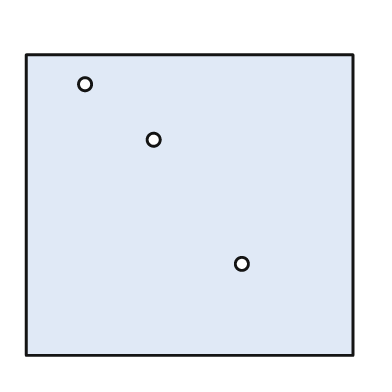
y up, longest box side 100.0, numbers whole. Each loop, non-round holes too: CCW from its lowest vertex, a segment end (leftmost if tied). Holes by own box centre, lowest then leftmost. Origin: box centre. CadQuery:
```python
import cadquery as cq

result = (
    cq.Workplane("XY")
    .moveTo(-50.0, -46.0)
    .lineTo(50.0, -46.0)
    .lineTo(50.0, 46.0)
    .lineTo(-50.0, 46.0)
    .close()
    .moveTo(16.0, -18.0)
    .circle(2.0)
    .moveTo(-11.0, 20.0)
    .circle(2.0)
    .moveTo(-32.0, 37.0)
    .circle(2.0)
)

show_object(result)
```